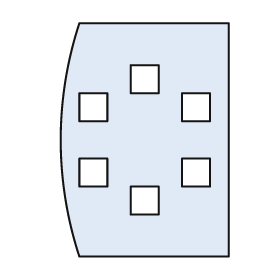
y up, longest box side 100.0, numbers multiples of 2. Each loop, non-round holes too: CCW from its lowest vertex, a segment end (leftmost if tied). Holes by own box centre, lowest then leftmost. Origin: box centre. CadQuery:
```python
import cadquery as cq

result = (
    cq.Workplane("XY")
    .moveTo(-28.0, -50.0)
    .lineTo(36.0, -50.0)
    .lineTo(36.0, 50.0)
    .lineTo(-28.0, 50.0)
    .threePointArc((-36.0, 0.0), (-28.0, -50.0))
    .close()
    .moveTo(-6.0, -32.0)
    .lineTo(6.0, -32.0)
    .lineTo(6.0, -20.0)
    .lineTo(-6.0, -20.0)
    .close()
    .moveTo(-28.0, -20.0)
    .lineTo(-16.0, -20.0)
    .lineTo(-16.0, -8.0)
    .lineTo(-28.0, -8.0)
    .close()
    .moveTo(16.0, -20.0)
    .lineTo(28.0, -20.0)
    .lineTo(28.0, -8.0)
    .lineTo(16.0, -8.0)
    .close()
    .moveTo(-28.0, 8.0)
    .lineTo(-16.0, 8.0)
    .lineTo(-16.0, 20.0)
    .lineTo(-28.0, 20.0)
    .close()
    .moveTo(16.0, 8.0)
    .lineTo(28.0, 8.0)
    .lineTo(28.0, 20.0)
    .lineTo(16.0, 20.0)
    .close()
    .moveTo(-6.0, 20.0)
    .lineTo(6.0, 20.0)
    .lineTo(6.0, 32.0)
    .lineTo(-6.0, 32.0)
    .close()
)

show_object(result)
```